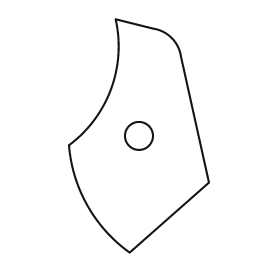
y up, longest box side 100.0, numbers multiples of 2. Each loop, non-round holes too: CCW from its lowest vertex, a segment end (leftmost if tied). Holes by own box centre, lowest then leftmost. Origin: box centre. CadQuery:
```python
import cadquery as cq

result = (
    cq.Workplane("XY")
    .moveTo(-4.0, -50.0)
    .lineTo(30.0, -20.0)
    .lineTo(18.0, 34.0)
    .threePointArc((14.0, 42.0), (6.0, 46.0))
    .lineTo(-10.0, 50.0)
    .threePointArc((-12.0, 20.0), (-30.0, -4.0))
    .threePointArc((-22.0, -30.0), (-4.0, -50.0))
    .close()
    .moveTo(0.0, 0.0)
    .circle(6.0)
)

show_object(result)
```